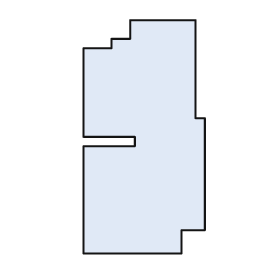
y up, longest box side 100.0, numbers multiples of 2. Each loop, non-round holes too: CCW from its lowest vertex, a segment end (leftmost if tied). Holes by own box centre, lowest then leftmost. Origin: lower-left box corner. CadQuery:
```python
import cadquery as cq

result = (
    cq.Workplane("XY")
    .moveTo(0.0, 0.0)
    .lineTo(42.0, 0.0)
    .lineTo(42.0, 10.0)
    .lineTo(52.0, 10.0)
    .lineTo(52.0, 58.0)
    .lineTo(48.0, 58.0)
    .lineTo(48.0, 100.0)
    .lineTo(20.0, 100.0)
    .lineTo(20.0, 92.0)
    .lineTo(12.0, 92.0)
    .lineTo(12.0, 88.0)
    .lineTo(0.0, 88.0)
    .lineTo(0.0, 50.0)
    .lineTo(22.0, 50.0)
    .lineTo(22.0, 46.0)
    .lineTo(0.0, 46.0)
    .close()
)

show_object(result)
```